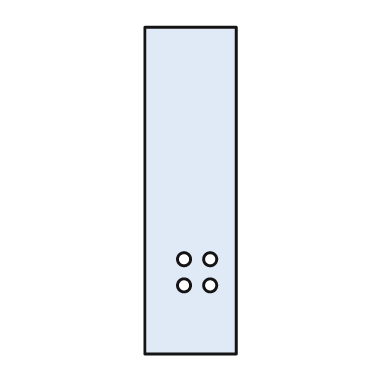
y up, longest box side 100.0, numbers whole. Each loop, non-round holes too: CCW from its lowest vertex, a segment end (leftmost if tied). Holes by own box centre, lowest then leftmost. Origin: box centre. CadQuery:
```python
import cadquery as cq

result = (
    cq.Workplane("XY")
    .moveTo(-14.0, -50.0)
    .lineTo(14.0, -50.0)
    .lineTo(14.0, 50.0)
    .lineTo(-14.0, 50.0)
    .close()
    .moveTo(-2.0, -29.0)
    .circle(2.0)
    .moveTo(6.0, -29.0)
    .circle(2.0)
    .moveTo(-2.0, -21.0)
    .circle(2.0)
    .moveTo(6.0, -21.0)
    .circle(2.0)
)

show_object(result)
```